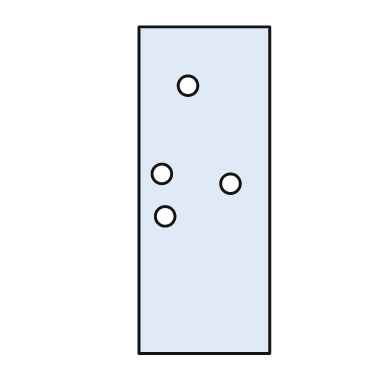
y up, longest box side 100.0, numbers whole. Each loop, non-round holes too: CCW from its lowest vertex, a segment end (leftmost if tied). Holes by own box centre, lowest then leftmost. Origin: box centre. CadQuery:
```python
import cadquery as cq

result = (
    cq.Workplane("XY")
    .moveTo(-20.0, -50.0)
    .lineTo(20.0, -50.0)
    .lineTo(20.0, 50.0)
    .lineTo(-20.0, 50.0)
    .close()
    .moveTo(-12.0, -8.0)
    .circle(3.0)
    .moveTo(8.0, 2.0)
    .circle(3.0)
    .moveTo(-13.0, 5.0)
    .circle(3.0)
    .moveTo(-5.0, 32.0)
    .circle(3.0)
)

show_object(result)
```